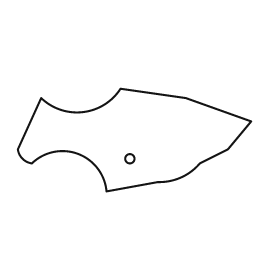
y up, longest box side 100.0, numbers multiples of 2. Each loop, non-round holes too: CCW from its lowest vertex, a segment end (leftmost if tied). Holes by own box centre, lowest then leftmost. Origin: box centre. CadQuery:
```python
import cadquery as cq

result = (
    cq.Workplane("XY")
    .moveTo(-12.0, -22.0)
    .lineTo(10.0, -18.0)
    .threePointArc((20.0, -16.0), (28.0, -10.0))
    .lineTo(40.0, -4.0)
    .lineTo(50.0, 8.0)
    .lineTo(22.0, 18.0)
    .lineTo(-6.0, 22.0)
    .threePointArc((-22.0, 12.0), (-40.0, 18.0))
    .lineTo(-50.0, -4.0)
    .threePointArc((-48.0, -8.0), (-44.0, -10.0))
    .threePointArc((-24.0, -6.0), (-12.0, -22.0))
    .close()
    .moveTo(-2.0, -8.0)
    .circle(2.0)
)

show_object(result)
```